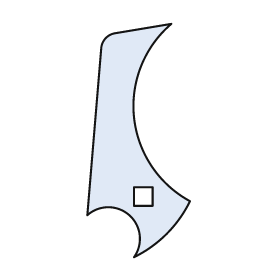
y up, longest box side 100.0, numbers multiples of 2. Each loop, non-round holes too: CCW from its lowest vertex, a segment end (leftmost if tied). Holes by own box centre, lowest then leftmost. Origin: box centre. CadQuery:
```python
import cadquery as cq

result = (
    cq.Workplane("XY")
    .moveTo(-2.0, -50.0)
    .threePointArc((12.0, -40.0), (22.0, -26.0))
    .threePointArc((-2.0, 10.0), (14.0, 50.0))
    .lineTo(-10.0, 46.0)
    .threePointArc((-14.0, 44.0), (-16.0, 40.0))
    .lineTo(-22.0, -32.0)
    .threePointArc((-4.0, -32.0), (-2.0, -50.0))
    .close()
    .moveTo(-2.0, -28.0)
    .lineTo(6.0, -28.0)
    .lineTo(6.0, -20.0)
    .lineTo(-2.0, -20.0)
    .close()
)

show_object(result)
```